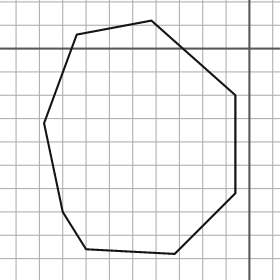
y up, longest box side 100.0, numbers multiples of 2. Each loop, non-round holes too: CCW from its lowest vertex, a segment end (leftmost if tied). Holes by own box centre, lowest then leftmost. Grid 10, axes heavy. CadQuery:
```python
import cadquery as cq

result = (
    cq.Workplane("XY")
    .moveTo(-32.0, -88.0)
    .lineTo(-6.0, -62.0)
    .lineTo(-6.0, -20.0)
    .lineTo(-42.0, 12.0)
    .lineTo(-74.0, 6.0)
    .lineTo(-88.0, -32.0)
    .lineTo(-80.0, -70.0)
    .lineTo(-70.0, -86.0)
    .close()
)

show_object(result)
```